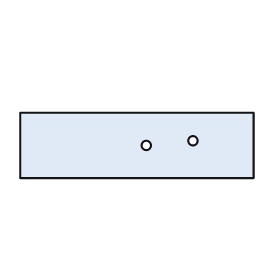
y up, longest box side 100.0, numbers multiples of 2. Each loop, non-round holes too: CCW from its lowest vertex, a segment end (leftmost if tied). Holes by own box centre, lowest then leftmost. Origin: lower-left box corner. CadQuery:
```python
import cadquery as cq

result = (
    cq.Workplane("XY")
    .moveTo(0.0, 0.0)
    .lineTo(100.0, 0.0)
    .lineTo(100.0, 28.0)
    .lineTo(0.0, 28.0)
    .close()
    .moveTo(54.0, 14.0)
    .circle(2.0)
    .moveTo(74.0, 16.0)
    .circle(2.0)
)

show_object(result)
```